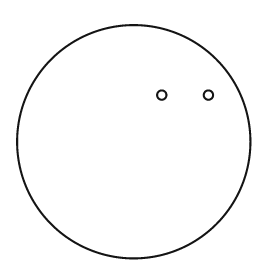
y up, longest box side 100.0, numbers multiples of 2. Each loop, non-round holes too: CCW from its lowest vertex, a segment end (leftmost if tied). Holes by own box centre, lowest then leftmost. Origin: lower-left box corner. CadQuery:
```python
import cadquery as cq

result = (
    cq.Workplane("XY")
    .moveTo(50.0, 50.0)
    .circle(50.0)
    .moveTo(62.0, 70.0)
    .circle(2.0)
    .moveTo(82.0, 70.0)
    .circle(2.0)
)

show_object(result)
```